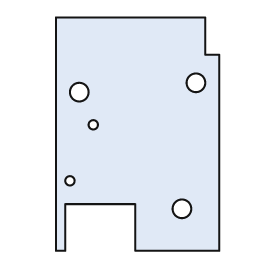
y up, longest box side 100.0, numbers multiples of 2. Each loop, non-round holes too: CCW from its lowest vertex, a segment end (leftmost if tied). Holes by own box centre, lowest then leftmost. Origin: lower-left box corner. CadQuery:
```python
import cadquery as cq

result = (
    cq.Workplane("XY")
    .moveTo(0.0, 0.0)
    .lineTo(4.0, 0.0)
    .lineTo(4.0, 20.0)
    .lineTo(34.0, 20.0)
    .lineTo(34.0, 0.0)
    .lineTo(70.0, 0.0)
    .lineTo(70.0, 84.0)
    .lineTo(64.0, 84.0)
    .lineTo(64.0, 100.0)
    .lineTo(0.0, 100.0)
    .close()
    .moveTo(54.0, 18.0)
    .circle(4.0)
    .moveTo(6.0, 30.0)
    .circle(2.0)
    .moveTo(16.0, 54.0)
    .circle(2.0)
    .moveTo(10.0, 68.0)
    .circle(4.0)
    .moveTo(60.0, 72.0)
    .circle(4.0)
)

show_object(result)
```